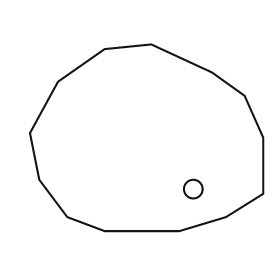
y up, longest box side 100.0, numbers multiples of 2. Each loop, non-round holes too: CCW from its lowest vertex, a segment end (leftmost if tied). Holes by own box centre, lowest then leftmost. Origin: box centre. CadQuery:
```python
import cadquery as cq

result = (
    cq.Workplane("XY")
    .moveTo(-18.0, -40.0)
    .lineTo(14.0, -40.0)
    .lineTo(34.0, -34.0)
    .lineTo(50.0, -24.0)
    .lineTo(50.0, 0.0)
    .lineTo(42.0, 18.0)
    .lineTo(28.0, 28.0)
    .lineTo(2.0, 40.0)
    .lineTo(-18.0, 38.0)
    .lineTo(-38.0, 24.0)
    .lineTo(-50.0, 2.0)
    .lineTo(-46.0, -18.0)
    .lineTo(-34.0, -34.0)
    .close()
    .moveTo(20.0, -22.0)
    .circle(4.0)
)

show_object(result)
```